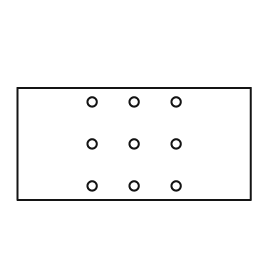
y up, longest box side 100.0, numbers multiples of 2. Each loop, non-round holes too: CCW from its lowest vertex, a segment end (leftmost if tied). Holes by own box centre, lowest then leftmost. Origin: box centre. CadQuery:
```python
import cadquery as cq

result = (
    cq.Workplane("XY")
    .moveTo(-50.0, -24.0)
    .lineTo(50.0, -24.0)
    .lineTo(50.0, 24.0)
    .lineTo(-50.0, 24.0)
    .close()
    .moveTo(-18.0, -18.0)
    .circle(2.0)
    .moveTo(0.0, -18.0)
    .circle(2.0)
    .moveTo(18.0, -18.0)
    .circle(2.0)
    .moveTo(-18.0, 0.0)
    .circle(2.0)
    .moveTo(0.0, 0.0)
    .circle(2.0)
    .moveTo(18.0, 0.0)
    .circle(2.0)
    .moveTo(-18.0, 18.0)
    .circle(2.0)
    .moveTo(0.0, 18.0)
    .circle(2.0)
    .moveTo(18.0, 18.0)
    .circle(2.0)
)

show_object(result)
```